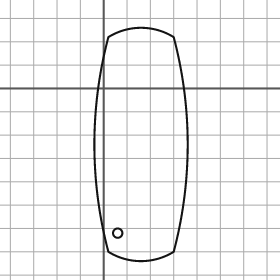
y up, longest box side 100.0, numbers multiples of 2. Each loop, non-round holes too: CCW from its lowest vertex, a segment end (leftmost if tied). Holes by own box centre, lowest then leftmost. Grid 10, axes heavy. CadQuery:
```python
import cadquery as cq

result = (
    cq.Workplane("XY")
    .moveTo(2.0, -70.0)
    .threePointArc((16.0, -74.0), (30.0, -70.0))
    .threePointArc((36.0, -24.0), (30.0, 22.0))
    .threePointArc((16.0, 26.0), (2.0, 22.0))
    .threePointArc((-4.0, -24.0), (2.0, -70.0))
    .close()
    .moveTo(6.0, -62.0)
    .circle(2.0)
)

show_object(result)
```